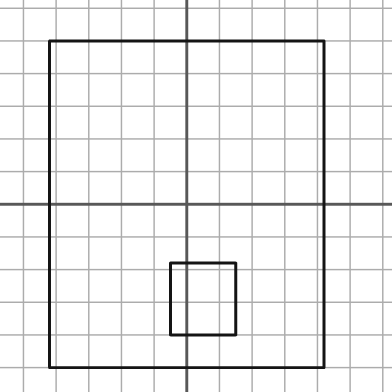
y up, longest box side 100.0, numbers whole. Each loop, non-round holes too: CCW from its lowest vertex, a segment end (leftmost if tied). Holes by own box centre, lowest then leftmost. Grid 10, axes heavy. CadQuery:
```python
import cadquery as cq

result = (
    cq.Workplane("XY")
    .moveTo(-42.0, -50.0)
    .lineTo(42.0, -50.0)
    .lineTo(42.0, 50.0)
    .lineTo(-42.0, 50.0)
    .close()
    .moveTo(-5.0, -40.0)
    .lineTo(15.0, -40.0)
    .lineTo(15.0, -18.0)
    .lineTo(-5.0, -18.0)
    .close()
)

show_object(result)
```